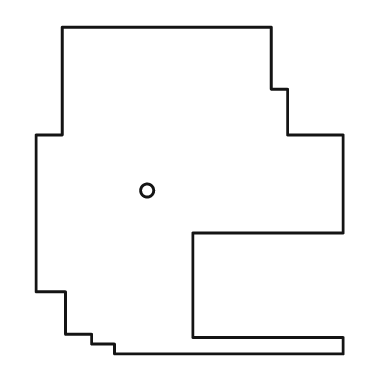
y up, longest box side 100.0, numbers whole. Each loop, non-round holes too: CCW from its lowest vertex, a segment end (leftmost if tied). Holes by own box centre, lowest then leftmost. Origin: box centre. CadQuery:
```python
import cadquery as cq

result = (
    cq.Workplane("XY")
    .moveTo(-23.0, -50.0)
    .lineTo(47.0, -50.0)
    .lineTo(47.0, -45.0)
    .lineTo(1.0, -45.0)
    .lineTo(1.0, -13.0)
    .lineTo(47.0, -13.0)
    .lineTo(47.0, 17.0)
    .lineTo(30.0, 17.0)
    .lineTo(30.0, 31.0)
    .lineTo(25.0, 31.0)
    .lineTo(25.0, 50.0)
    .lineTo(-39.0, 50.0)
    .lineTo(-39.0, 17.0)
    .lineTo(-47.0, 17.0)
    .lineTo(-47.0, -31.0)
    .lineTo(-38.0, -31.0)
    .lineTo(-38.0, -44.0)
    .lineTo(-30.0, -44.0)
    .lineTo(-30.0, -47.0)
    .lineTo(-23.0, -47.0)
    .close()
    .moveTo(-13.0, 0.0)
    .circle(2.0)
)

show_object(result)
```